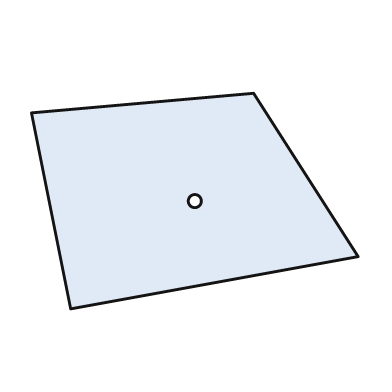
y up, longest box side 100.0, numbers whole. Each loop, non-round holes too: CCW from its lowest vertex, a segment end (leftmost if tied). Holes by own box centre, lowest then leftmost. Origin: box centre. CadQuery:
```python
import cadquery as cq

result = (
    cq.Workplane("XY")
    .moveTo(-38.0, -33.0)
    .lineTo(50.0, -17.0)
    .lineTo(18.0, 33.0)
    .lineTo(-50.0, 27.0)
    .close()
    .moveTo(0.0, 0.0)
    .circle(2.0)
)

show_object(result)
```